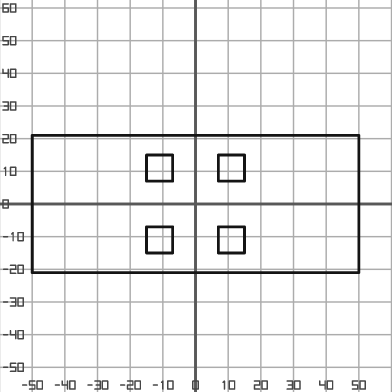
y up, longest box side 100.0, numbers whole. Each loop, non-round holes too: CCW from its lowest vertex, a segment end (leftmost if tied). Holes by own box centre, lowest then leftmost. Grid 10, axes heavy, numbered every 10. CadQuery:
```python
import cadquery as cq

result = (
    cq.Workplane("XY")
    .moveTo(-50.0, -21.0)
    .lineTo(50.0, -21.0)
    .lineTo(50.0, 21.0)
    .lineTo(-50.0, 21.0)
    .close()
    .moveTo(-15.0, -15.0)
    .lineTo(-7.0, -15.0)
    .lineTo(-7.0, -7.0)
    .lineTo(-15.0, -7.0)
    .close()
    .moveTo(7.0, -15.0)
    .lineTo(15.0, -15.0)
    .lineTo(15.0, -7.0)
    .lineTo(7.0, -7.0)
    .close()
    .moveTo(-15.0, 7.0)
    .lineTo(-7.0, 7.0)
    .lineTo(-7.0, 15.0)
    .lineTo(-15.0, 15.0)
    .close()
    .moveTo(7.0, 7.0)
    .lineTo(15.0, 7.0)
    .lineTo(15.0, 15.0)
    .lineTo(7.0, 15.0)
    .close()
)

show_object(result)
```